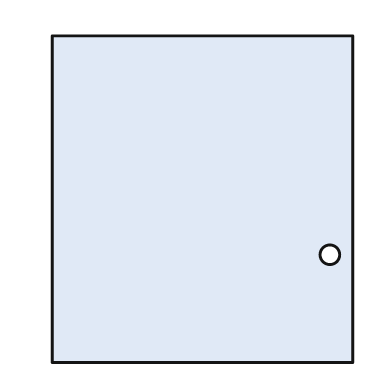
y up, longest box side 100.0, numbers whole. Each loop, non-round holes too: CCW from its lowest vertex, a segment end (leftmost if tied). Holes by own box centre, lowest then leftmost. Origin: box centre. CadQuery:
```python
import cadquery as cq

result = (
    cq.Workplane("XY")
    .moveTo(-46.0, -50.0)
    .lineTo(46.0, -50.0)
    .lineTo(46.0, 50.0)
    .lineTo(-46.0, 50.0)
    .close()
    .moveTo(39.0, -17.0)
    .circle(3.0)
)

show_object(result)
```